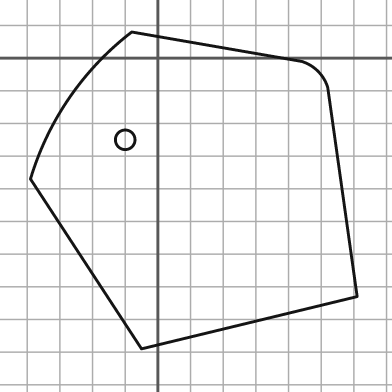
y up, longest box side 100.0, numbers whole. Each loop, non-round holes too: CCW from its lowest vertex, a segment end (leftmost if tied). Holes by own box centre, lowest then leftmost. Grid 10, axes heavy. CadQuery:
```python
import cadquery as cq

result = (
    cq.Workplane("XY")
    .moveTo(-5.0, -89.0)
    .lineTo(61.0, -73.0)
    .lineTo(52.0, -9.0)
    .threePointArc((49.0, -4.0), (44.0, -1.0))
    .lineTo(-8.0, 8.0)
    .threePointArc((-27.0, -12.0), (-39.0, -37.0))
    .close()
    .moveTo(-10.0, -25.0)
    .circle(3.0)
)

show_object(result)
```